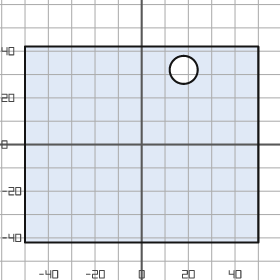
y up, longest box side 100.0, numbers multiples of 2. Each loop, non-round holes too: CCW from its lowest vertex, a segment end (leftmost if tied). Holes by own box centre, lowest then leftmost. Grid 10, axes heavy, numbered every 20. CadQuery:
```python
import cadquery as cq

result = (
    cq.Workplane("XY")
    .moveTo(-50.0, -42.0)
    .lineTo(50.0, -42.0)
    .lineTo(50.0, 42.0)
    .lineTo(-50.0, 42.0)
    .close()
    .moveTo(18.0, 32.0)
    .circle(6.0)
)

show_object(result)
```